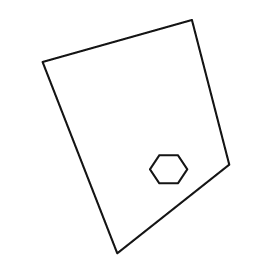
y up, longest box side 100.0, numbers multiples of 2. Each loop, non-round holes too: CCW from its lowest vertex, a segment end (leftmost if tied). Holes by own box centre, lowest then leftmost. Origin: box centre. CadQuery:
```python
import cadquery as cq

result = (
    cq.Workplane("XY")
    .moveTo(-8.0, -50.0)
    .lineTo(40.0, -12.0)
    .lineTo(24.0, 50.0)
    .lineTo(-40.0, 32.0)
    .close()
    .moveTo(10.0, -20.0)
    .lineTo(18.0, -20.0)
    .lineTo(22.0, -14.0)
    .lineTo(18.0, -8.0)
    .lineTo(10.0, -8.0)
    .lineTo(6.0, -14.0)
    .close()
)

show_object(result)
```